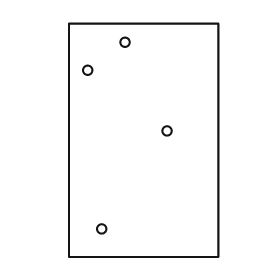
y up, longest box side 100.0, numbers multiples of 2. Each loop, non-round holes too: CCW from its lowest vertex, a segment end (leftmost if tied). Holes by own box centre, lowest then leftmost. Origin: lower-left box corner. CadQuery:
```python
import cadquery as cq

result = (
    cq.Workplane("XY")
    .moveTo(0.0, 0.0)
    .lineTo(64.0, 0.0)
    .lineTo(64.0, 100.0)
    .lineTo(0.0, 100.0)
    .close()
    .moveTo(14.0, 12.0)
    .circle(2.0)
    .moveTo(42.0, 54.0)
    .circle(2.0)
    .moveTo(8.0, 80.0)
    .circle(2.0)
    .moveTo(24.0, 92.0)
    .circle(2.0)
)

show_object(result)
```